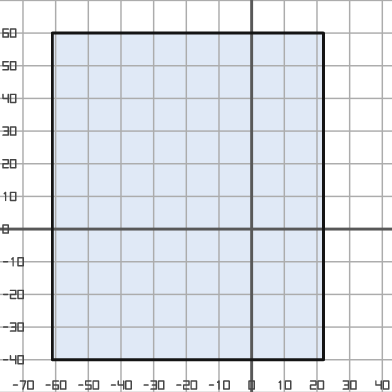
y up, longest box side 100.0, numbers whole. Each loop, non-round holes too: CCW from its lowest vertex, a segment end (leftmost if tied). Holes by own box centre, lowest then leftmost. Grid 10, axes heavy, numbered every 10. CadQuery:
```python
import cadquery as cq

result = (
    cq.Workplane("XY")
    .moveTo(-61.0, -40.0)
    .lineTo(22.0, -40.0)
    .lineTo(22.0, 60.0)
    .lineTo(-61.0, 60.0)
    .close()
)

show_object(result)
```